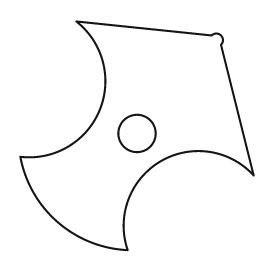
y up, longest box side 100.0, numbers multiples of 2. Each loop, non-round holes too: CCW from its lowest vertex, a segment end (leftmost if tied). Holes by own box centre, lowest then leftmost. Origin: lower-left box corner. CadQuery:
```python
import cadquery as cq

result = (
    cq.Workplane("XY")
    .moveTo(46.0, 0.0)
    .threePointArc((60.0, 38.0), (100.0, 32.0))
    .lineTo(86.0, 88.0)
    .threePointArc((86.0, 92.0), (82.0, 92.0))
    .lineTo(24.0, 98.0)
    .threePointArc((34.0, 60.0), (0.0, 40.0))
    .threePointArc((16.0, 12.0), (46.0, 0.0))
    .close()
    .moveTo(50.0, 50.0)
    .circle(8.0)
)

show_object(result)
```